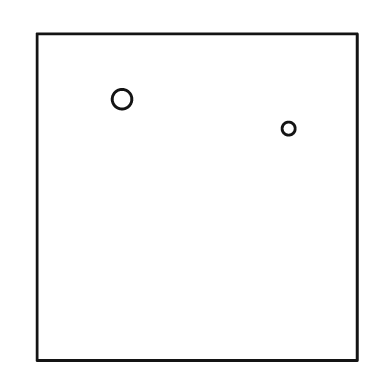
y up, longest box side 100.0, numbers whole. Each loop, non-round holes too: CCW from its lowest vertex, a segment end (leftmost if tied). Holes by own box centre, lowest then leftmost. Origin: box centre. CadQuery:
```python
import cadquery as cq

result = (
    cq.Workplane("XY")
    .moveTo(-49.0, -50.0)
    .lineTo(49.0, -50.0)
    .lineTo(49.0, 50.0)
    .lineTo(-49.0, 50.0)
    .close()
    .moveTo(28.0, 21.0)
    .circle(2.0)
    .moveTo(-23.0, 30.0)
    .circle(3.0)
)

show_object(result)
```